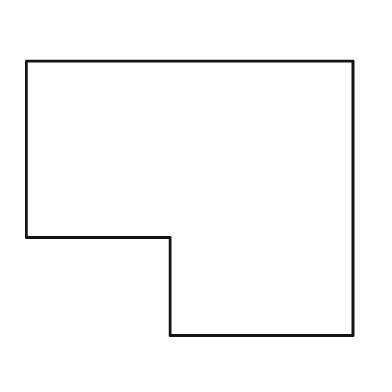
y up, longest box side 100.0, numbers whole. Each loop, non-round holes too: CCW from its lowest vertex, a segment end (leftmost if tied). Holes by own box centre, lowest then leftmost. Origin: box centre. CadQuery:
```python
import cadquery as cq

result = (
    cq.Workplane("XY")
    .moveTo(-6.0, -42.0)
    .lineTo(50.0, -42.0)
    .lineTo(50.0, 42.0)
    .lineTo(-50.0, 42.0)
    .lineTo(-50.0, -12.0)
    .lineTo(-6.0, -12.0)
    .close()
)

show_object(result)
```